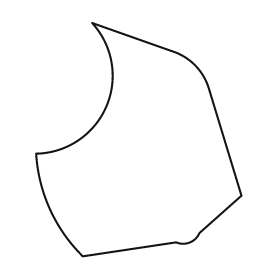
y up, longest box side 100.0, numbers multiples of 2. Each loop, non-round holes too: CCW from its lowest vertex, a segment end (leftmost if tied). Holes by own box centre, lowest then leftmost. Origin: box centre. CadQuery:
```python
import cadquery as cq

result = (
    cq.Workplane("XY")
    .moveTo(-24.0, -50.0)
    .lineTo(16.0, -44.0)
    .threePointArc((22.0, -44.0), (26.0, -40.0))
    .lineTo(44.0, -24.0)
    .lineTo(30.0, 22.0)
    .threePointArc((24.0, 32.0), (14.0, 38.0))
    .lineTo(-20.0, 50.0)
    .threePointArc((-14.0, 14.0), (-44.0, -6.0))
    .threePointArc((-38.0, -30.0), (-24.0, -50.0))
    .close()
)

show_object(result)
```